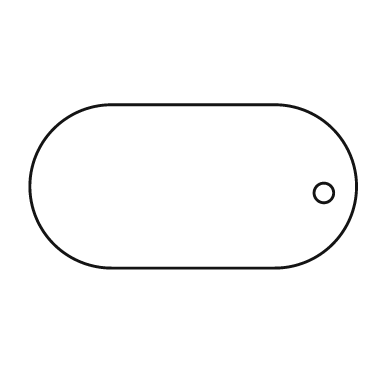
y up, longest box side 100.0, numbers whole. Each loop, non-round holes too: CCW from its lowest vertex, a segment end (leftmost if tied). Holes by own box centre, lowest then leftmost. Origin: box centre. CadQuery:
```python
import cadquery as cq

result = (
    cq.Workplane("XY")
    .moveTo(-25.0, -25.0)
    .lineTo(25.0, -25.0)
    .threePointArc((50.0, 0.0), (25.0, 25.0))
    .lineTo(-25.0, 25.0)
    .threePointArc((-50.0, 0.0), (-25.0, -25.0))
    .close()
    .moveTo(40.0, -2.0)
    .circle(3.0)
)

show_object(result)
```